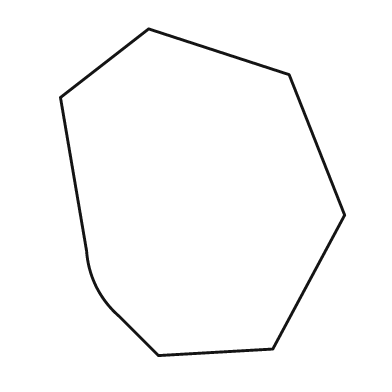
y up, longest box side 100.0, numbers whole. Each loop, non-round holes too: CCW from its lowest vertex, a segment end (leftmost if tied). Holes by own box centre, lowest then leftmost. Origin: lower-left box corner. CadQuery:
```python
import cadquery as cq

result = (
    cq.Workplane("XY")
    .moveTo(30.0, 0.0)
    .lineTo(65.0, 2.0)
    .lineTo(87.0, 43.0)
    .lineTo(70.0, 86.0)
    .lineTo(27.0, 100.0)
    .lineTo(0.0, 79.0)
    .lineTo(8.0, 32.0)
    .threePointArc((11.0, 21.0), (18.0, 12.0))
    .close()
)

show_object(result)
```